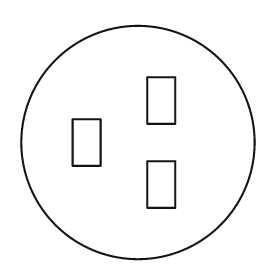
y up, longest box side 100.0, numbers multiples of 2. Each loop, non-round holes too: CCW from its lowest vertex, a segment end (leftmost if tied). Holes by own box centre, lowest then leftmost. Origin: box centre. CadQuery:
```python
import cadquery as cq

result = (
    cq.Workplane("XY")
    .moveTo(0.0, 0.0)
    .circle(50.0)
    .moveTo(4.0, -28.0)
    .lineTo(16.0, -28.0)
    .lineTo(16.0, -8.0)
    .lineTo(4.0, -8.0)
    .close()
    .moveTo(-28.0, -10.0)
    .lineTo(-16.0, -10.0)
    .lineTo(-16.0, 10.0)
    .lineTo(-28.0, 10.0)
    .close()
    .moveTo(4.0, 8.0)
    .lineTo(16.0, 8.0)
    .lineTo(16.0, 28.0)
    .lineTo(4.0, 28.0)
    .close()
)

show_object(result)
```